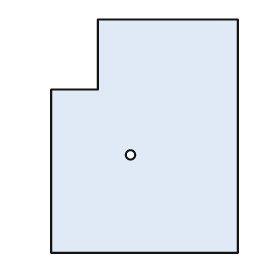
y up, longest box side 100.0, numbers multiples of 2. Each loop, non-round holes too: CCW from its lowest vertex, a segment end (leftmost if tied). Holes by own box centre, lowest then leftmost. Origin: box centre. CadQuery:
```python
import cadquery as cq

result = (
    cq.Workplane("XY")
    .moveTo(-40.0, -50.0)
    .lineTo(40.0, -50.0)
    .lineTo(40.0, 50.0)
    .lineTo(-20.0, 50.0)
    .lineTo(-20.0, 20.0)
    .lineTo(-40.0, 20.0)
    .close()
    .moveTo(-6.0, -8.0)
    .circle(2.0)
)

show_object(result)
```